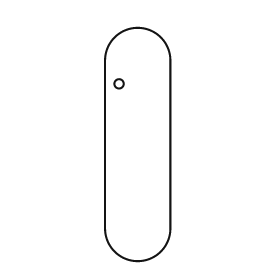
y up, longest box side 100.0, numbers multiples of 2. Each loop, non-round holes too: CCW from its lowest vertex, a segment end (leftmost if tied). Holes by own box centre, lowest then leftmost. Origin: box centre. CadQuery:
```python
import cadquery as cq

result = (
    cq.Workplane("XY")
    .moveTo(-14.0, -36.0)
    .threePointArc((0.0, -50.0), (14.0, -36.0))
    .lineTo(14.0, 36.0)
    .threePointArc((0.0, 50.0), (-14.0, 36.0))
    .close()
    .moveTo(-8.0, 26.0)
    .circle(2.0)
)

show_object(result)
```